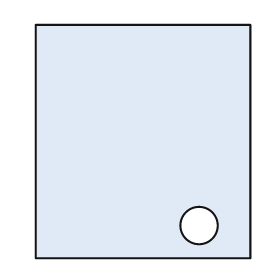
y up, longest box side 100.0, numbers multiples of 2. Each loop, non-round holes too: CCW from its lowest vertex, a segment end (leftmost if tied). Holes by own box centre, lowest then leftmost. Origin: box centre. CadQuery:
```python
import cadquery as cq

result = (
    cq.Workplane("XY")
    .moveTo(-46.0, -50.0)
    .lineTo(46.0, -50.0)
    .lineTo(46.0, 50.0)
    .lineTo(-46.0, 50.0)
    .close()
    .moveTo(24.0, -36.0)
    .circle(8.0)
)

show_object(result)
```